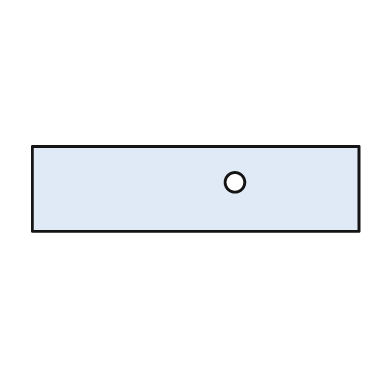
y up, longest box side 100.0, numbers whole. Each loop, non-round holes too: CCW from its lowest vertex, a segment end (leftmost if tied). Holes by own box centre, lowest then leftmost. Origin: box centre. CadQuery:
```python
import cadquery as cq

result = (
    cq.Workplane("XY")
    .moveTo(-50.0, -13.0)
    .lineTo(50.0, -13.0)
    .lineTo(50.0, 13.0)
    .lineTo(-50.0, 13.0)
    .close()
    .moveTo(12.0, 2.0)
    .circle(3.0)
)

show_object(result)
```